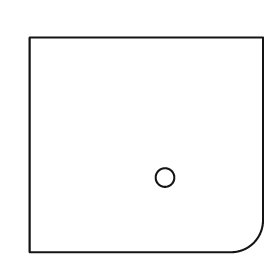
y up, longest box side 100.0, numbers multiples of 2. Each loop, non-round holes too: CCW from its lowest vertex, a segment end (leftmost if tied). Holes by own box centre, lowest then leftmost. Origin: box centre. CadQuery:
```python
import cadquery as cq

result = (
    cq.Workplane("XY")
    .moveTo(-50.0, -46.0)
    .lineTo(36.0, -46.0)
    .threePointArc((46.0, -42.0), (50.0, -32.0))
    .lineTo(50.0, 46.0)
    .lineTo(-50.0, 46.0)
    .close()
    .moveTo(8.0, -14.0)
    .circle(4.0)
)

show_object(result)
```